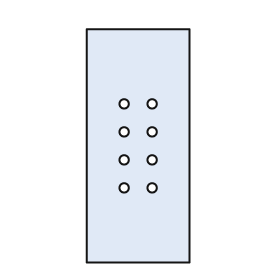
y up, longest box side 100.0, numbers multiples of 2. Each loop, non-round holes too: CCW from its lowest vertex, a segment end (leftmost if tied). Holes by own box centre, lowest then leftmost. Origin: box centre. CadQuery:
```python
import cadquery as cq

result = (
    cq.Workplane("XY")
    .moveTo(-22.0, -50.0)
    .lineTo(22.0, -50.0)
    .lineTo(22.0, 50.0)
    .lineTo(-22.0, 50.0)
    .close()
    .moveTo(-6.0, -18.0)
    .circle(2.0)
    .moveTo(6.0, -18.0)
    .circle(2.0)
    .moveTo(-6.0, -6.0)
    .circle(2.0)
    .moveTo(6.0, -6.0)
    .circle(2.0)
    .moveTo(-6.0, 6.0)
    .circle(2.0)
    .moveTo(6.0, 6.0)
    .circle(2.0)
    .moveTo(-6.0, 18.0)
    .circle(2.0)
    .moveTo(6.0, 18.0)
    .circle(2.0)
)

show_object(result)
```